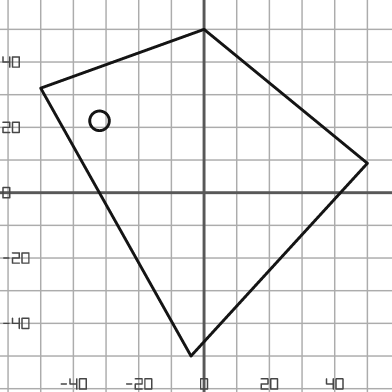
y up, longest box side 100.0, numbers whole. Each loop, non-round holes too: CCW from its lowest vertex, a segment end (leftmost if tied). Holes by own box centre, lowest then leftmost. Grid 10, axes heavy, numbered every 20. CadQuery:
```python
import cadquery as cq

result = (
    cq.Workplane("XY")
    .moveTo(-4.0, -50.0)
    .lineTo(50.0, 9.0)
    .lineTo(0.0, 50.0)
    .lineTo(-50.0, 32.0)
    .close()
    .moveTo(-32.0, 22.0)
    .circle(3.0)
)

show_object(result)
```